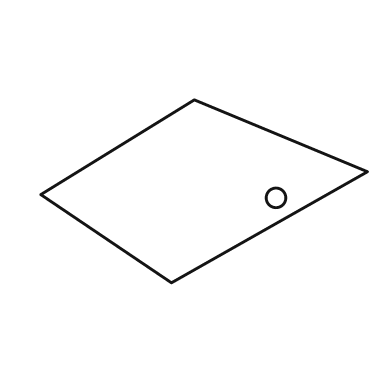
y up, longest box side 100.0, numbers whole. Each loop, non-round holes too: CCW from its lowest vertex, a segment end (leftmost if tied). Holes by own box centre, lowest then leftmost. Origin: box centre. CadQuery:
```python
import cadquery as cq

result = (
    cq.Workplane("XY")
    .moveTo(-10.0, -28.0)
    .lineTo(50.0, 6.0)
    .lineTo(-3.0, 28.0)
    .lineTo(-50.0, -1.0)
    .close()
    .moveTo(22.0, -2.0)
    .circle(3.0)
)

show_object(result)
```